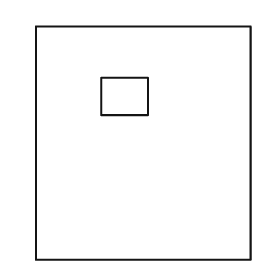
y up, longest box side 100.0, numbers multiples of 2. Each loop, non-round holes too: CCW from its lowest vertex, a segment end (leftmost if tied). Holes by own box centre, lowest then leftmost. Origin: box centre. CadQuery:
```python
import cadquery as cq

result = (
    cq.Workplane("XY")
    .moveTo(-46.0, -50.0)
    .lineTo(46.0, -50.0)
    .lineTo(46.0, 50.0)
    .lineTo(-46.0, 50.0)
    .close()
    .moveTo(-18.0, 12.0)
    .lineTo(2.0, 12.0)
    .lineTo(2.0, 28.0)
    .lineTo(-18.0, 28.0)
    .close()
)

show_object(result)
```